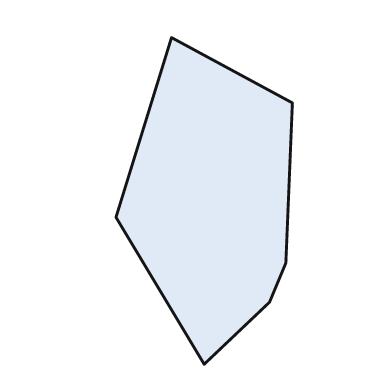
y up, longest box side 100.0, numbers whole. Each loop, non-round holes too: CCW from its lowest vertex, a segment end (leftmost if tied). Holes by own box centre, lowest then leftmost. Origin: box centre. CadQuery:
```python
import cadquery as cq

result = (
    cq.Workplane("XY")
    .moveTo(0.0, -50.0)
    .lineTo(20.0, -31.0)
    .lineTo(25.0, -19.0)
    .lineTo(27.0, 30.0)
    .lineTo(-10.0, 50.0)
    .lineTo(-27.0, -5.0)
    .close()
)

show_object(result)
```